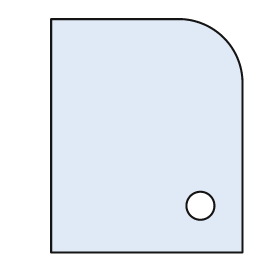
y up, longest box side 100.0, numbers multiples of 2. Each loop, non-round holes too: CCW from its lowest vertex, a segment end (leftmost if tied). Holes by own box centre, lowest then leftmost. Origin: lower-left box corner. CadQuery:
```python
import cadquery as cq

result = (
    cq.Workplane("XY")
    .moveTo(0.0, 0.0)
    .lineTo(82.0, 0.0)
    .lineTo(82.0, 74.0)
    .threePointArc((74.0, 92.0), (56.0, 100.0))
    .lineTo(0.0, 100.0)
    .close()
    .moveTo(64.0, 20.0)
    .circle(6.0)
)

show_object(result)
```